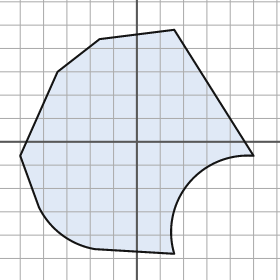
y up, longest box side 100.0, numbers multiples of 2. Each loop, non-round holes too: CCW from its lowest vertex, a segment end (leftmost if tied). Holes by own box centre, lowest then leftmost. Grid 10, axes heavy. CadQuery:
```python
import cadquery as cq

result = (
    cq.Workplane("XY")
    .moveTo(16.0, -48.0)
    .threePointArc((22.0, -18.0), (50.0, -6.0))
    .lineTo(16.0, 48.0)
    .lineTo(-16.0, 44.0)
    .lineTo(-34.0, 30.0)
    .lineTo(-50.0, -6.0)
    .lineTo(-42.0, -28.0)
    .threePointArc((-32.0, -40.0), (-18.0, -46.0))
    .close()
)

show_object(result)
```